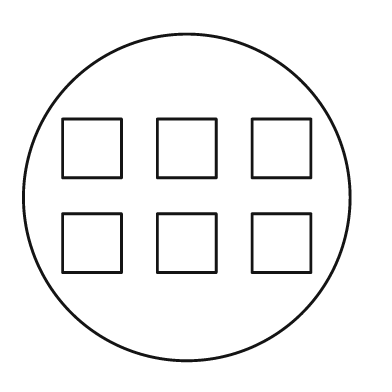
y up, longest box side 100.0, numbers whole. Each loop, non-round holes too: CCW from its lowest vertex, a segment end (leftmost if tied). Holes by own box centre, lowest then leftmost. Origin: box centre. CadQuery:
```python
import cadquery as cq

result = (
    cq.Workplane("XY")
    .moveTo(0.0, 0.0)
    .circle(50.0)
    .moveTo(-38.0, -23.0)
    .lineTo(-20.0, -23.0)
    .lineTo(-20.0, -5.0)
    .lineTo(-38.0, -5.0)
    .close()
    .moveTo(-9.0, -23.0)
    .lineTo(9.0, -23.0)
    .lineTo(9.0, -5.0)
    .lineTo(-9.0, -5.0)
    .close()
    .moveTo(20.0, -23.0)
    .lineTo(38.0, -23.0)
    .lineTo(38.0, -5.0)
    .lineTo(20.0, -5.0)
    .close()
    .moveTo(-38.0, 6.0)
    .lineTo(-20.0, 6.0)
    .lineTo(-20.0, 24.0)
    .lineTo(-38.0, 24.0)
    .close()
    .moveTo(-9.0, 6.0)
    .lineTo(9.0, 6.0)
    .lineTo(9.0, 24.0)
    .lineTo(-9.0, 24.0)
    .close()
    .moveTo(20.0, 6.0)
    .lineTo(38.0, 6.0)
    .lineTo(38.0, 24.0)
    .lineTo(20.0, 24.0)
    .close()
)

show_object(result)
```